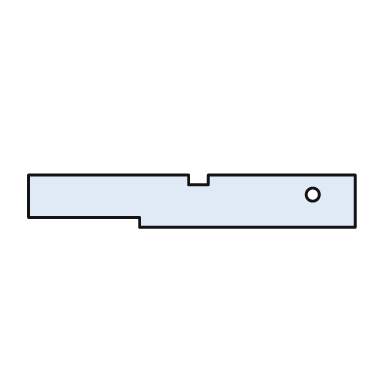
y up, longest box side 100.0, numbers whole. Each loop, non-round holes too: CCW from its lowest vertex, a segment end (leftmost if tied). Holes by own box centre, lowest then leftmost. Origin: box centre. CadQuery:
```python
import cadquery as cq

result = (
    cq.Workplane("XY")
    .moveTo(-16.0, -8.0)
    .lineTo(50.0, -8.0)
    .lineTo(50.0, 8.0)
    .lineTo(5.0, 8.0)
    .lineTo(5.0, 5.0)
    .lineTo(-1.0, 5.0)
    .lineTo(-1.0, 8.0)
    .lineTo(-50.0, 8.0)
    .lineTo(-50.0, -5.0)
    .lineTo(-16.0, -5.0)
    .close()
    .moveTo(37.0, 2.0)
    .circle(2.0)
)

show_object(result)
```